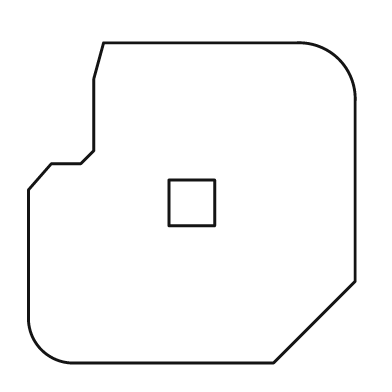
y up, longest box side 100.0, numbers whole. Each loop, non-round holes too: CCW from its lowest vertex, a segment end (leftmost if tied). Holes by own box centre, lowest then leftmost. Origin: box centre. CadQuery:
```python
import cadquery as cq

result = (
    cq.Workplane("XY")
    .moveTo(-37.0, -49.0)
    .lineTo(25.0, -49.0)
    .lineTo(50.0, -24.0)
    .lineTo(50.0, 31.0)
    .threePointArc((45.0, 44.0), (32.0, 49.0))
    .lineTo(-27.0, 49.0)
    .lineTo(-30.0, 38.0)
    .lineTo(-30.0, 16.0)
    .lineTo(-34.0, 12.0)
    .lineTo(-43.0, 12.0)
    .lineTo(-50.0, 4.0)
    .lineTo(-50.0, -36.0)
    .threePointArc((-46.0, -45.0), (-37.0, -49.0))
    .close()
    .moveTo(-7.0, -7.0)
    .lineTo(7.0, -7.0)
    .lineTo(7.0, 7.0)
    .lineTo(-7.0, 7.0)
    .close()
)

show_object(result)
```